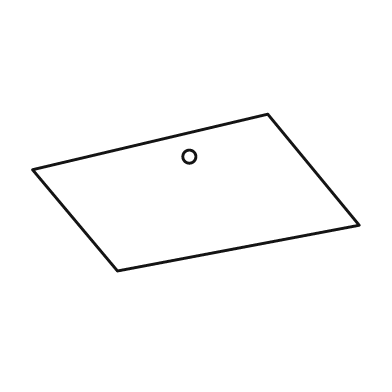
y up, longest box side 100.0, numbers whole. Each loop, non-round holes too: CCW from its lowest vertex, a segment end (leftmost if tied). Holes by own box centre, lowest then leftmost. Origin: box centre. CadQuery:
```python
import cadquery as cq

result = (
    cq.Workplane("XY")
    .moveTo(-24.0, -24.0)
    .lineTo(50.0, -10.0)
    .lineTo(22.0, 24.0)
    .lineTo(-50.0, 7.0)
    .close()
    .moveTo(-2.0, 11.0)
    .circle(2.0)
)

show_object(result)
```